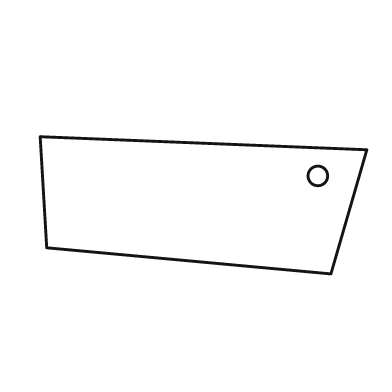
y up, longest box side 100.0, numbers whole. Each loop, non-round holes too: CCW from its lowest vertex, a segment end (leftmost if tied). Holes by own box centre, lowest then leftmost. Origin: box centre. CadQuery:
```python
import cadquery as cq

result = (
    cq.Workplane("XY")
    .moveTo(39.0, -21.0)
    .lineTo(50.0, 17.0)
    .lineTo(-50.0, 21.0)
    .lineTo(-48.0, -13.0)
    .close()
    .moveTo(35.0, 9.0)
    .circle(3.0)
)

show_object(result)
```